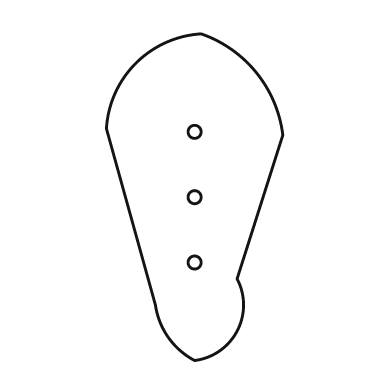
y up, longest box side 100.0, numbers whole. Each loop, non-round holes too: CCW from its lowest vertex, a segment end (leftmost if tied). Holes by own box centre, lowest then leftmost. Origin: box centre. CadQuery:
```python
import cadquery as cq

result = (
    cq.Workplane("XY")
    .moveTo(0.0, -50.0)
    .threePointArc((13.0, -41.0), (13.0, -25.0))
    .lineTo(27.0, 19.0)
    .threePointArc((19.0, 38.0), (2.0, 50.0))
    .threePointArc((-18.0, 41.0), (-27.0, 21.0))
    .lineTo(-12.0, -33.0)
    .threePointArc((-8.0, -43.0), (0.0, -50.0))
    .close()
    .moveTo(0.0, -20.0)
    .circle(2.0)
    .moveTo(0.0, 0.0)
    .circle(2.0)
    .moveTo(0.0, 20.0)
    .circle(2.0)
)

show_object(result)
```